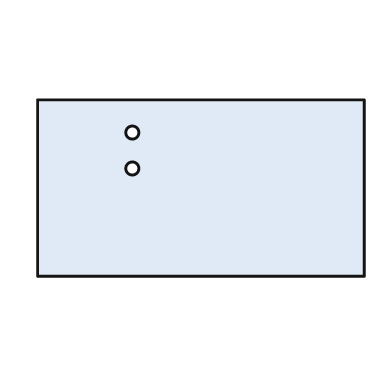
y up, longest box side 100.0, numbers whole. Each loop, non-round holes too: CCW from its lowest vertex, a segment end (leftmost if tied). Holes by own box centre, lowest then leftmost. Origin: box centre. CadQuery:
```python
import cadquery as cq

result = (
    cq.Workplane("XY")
    .moveTo(-50.0, -27.0)
    .lineTo(50.0, -27.0)
    .lineTo(50.0, 27.0)
    .lineTo(-50.0, 27.0)
    .close()
    .moveTo(-21.0, 6.0)
    .circle(2.0)
    .moveTo(-21.0, 17.0)
    .circle(2.0)
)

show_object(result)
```